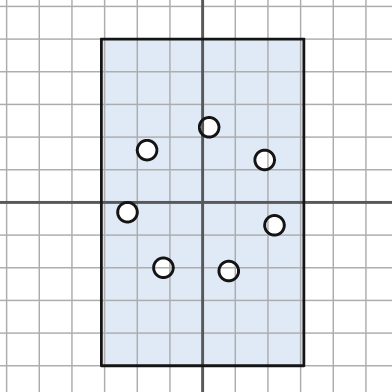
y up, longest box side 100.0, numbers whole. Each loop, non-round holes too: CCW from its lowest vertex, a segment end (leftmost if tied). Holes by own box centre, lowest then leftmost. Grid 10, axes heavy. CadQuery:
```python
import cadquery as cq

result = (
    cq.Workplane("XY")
    .moveTo(-31.0, -50.0)
    .lineTo(31.0, -50.0)
    .lineTo(31.0, 50.0)
    .lineTo(-31.0, 50.0)
    .close()
    .moveTo(8.0, -21.0)
    .circle(3.0)
    .moveTo(-12.0, -20.0)
    .circle(3.0)
    .moveTo(22.0, -7.0)
    .circle(3.0)
    .moveTo(-23.0, -3.0)
    .circle(3.0)
    .moveTo(19.0, 13.0)
    .circle(3.0)
    .moveTo(-17.0, 16.0)
    .circle(3.0)
    .moveTo(2.0, 23.0)
    .circle(3.0)
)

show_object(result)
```